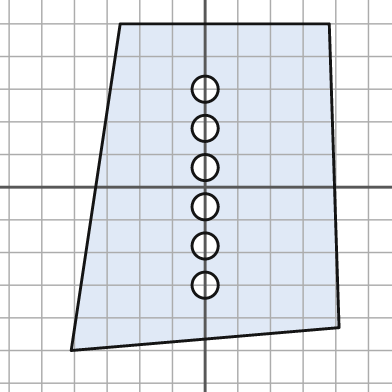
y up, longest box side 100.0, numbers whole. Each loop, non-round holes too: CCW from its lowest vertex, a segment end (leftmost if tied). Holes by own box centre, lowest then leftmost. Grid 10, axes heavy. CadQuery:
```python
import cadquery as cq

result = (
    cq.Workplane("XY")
    .moveTo(-41.0, -50.0)
    .lineTo(41.0, -43.0)
    .lineTo(38.0, 50.0)
    .lineTo(-26.0, 50.0)
    .close()
    .moveTo(0.0, -30.0)
    .circle(4.0)
    .moveTo(0.0, -18.0)
    .circle(4.0)
    .moveTo(0.0, -6.0)
    .circle(4.0)
    .moveTo(0.0, 6.0)
    .circle(4.0)
    .moveTo(0.0, 18.0)
    .circle(4.0)
    .moveTo(0.0, 30.0)
    .circle(4.0)
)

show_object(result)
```